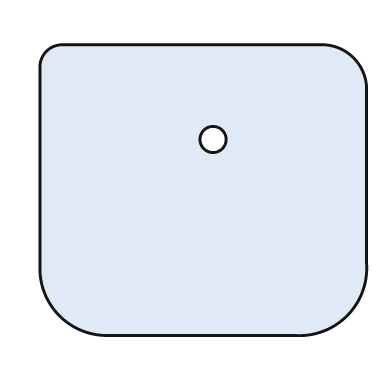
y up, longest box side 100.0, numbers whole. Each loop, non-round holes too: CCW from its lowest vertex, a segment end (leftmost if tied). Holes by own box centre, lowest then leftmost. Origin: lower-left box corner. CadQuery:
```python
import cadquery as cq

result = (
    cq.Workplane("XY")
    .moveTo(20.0, 0.0)
    .lineTo(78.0, 0.0)
    .threePointArc((94.0, 6.0), (100.0, 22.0))
    .lineTo(100.0, 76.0)
    .threePointArc((96.0, 85.0), (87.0, 89.0))
    .lineTo(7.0, 89.0)
    .threePointArc((2.0, 87.0), (0.0, 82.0))
    .lineTo(0.0, 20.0)
    .threePointArc((6.0, 6.0), (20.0, 0.0))
    .close()
    .moveTo(53.0, 60.0)
    .circle(4.0)
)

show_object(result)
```